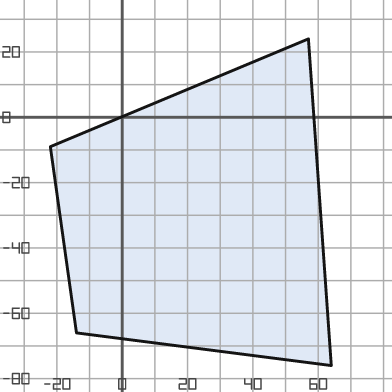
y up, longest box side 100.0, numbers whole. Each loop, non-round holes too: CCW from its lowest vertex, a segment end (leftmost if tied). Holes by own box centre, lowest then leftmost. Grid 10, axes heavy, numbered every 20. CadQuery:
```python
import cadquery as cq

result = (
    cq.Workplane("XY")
    .moveTo(64.0, -76.0)
    .lineTo(57.0, 24.0)
    .lineTo(-22.0, -9.0)
    .lineTo(-14.0, -66.0)
    .close()
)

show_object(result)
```